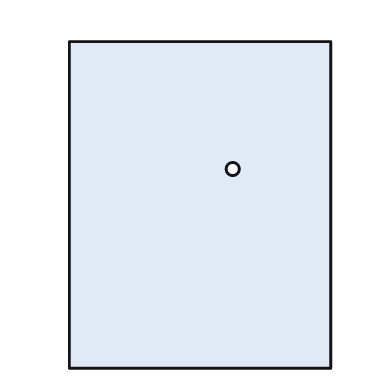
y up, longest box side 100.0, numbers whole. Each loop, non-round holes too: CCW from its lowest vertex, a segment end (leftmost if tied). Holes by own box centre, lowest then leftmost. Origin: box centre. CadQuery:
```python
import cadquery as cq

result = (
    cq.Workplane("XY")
    .moveTo(-40.0, -50.0)
    .lineTo(40.0, -50.0)
    .lineTo(40.0, 50.0)
    .lineTo(-40.0, 50.0)
    .close()
    .moveTo(10.0, 11.0)
    .circle(2.0)
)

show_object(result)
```